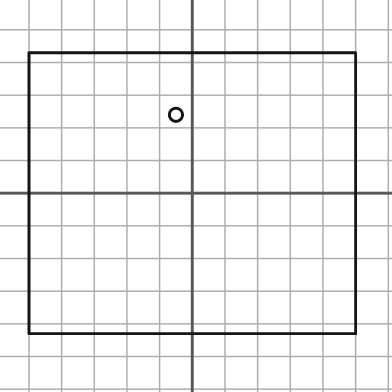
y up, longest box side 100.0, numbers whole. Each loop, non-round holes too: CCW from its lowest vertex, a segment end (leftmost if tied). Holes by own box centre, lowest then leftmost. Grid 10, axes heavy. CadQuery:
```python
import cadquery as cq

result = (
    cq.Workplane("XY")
    .moveTo(-50.0, -43.0)
    .lineTo(50.0, -43.0)
    .lineTo(50.0, 43.0)
    .lineTo(-50.0, 43.0)
    .close()
    .moveTo(-5.0, 24.0)
    .circle(2.0)
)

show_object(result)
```